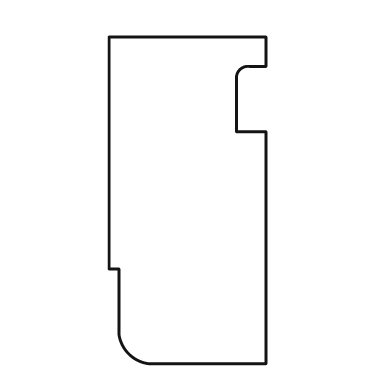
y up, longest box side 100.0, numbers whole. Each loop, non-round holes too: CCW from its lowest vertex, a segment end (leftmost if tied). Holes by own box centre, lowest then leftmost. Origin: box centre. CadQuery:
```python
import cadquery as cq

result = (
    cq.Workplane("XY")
    .moveTo(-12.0, -50.0)
    .lineTo(24.0, -50.0)
    .lineTo(24.0, 21.0)
    .lineTo(15.0, 21.0)
    .lineTo(15.0, 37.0)
    .threePointArc((16.0, 40.0), (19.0, 41.0))
    .lineTo(24.0, 41.0)
    .lineTo(24.0, 50.0)
    .lineTo(-24.0, 50.0)
    .lineTo(-24.0, -21.0)
    .lineTo(-21.0, -21.0)
    .lineTo(-21.0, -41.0)
    .threePointArc((-18.0, -47.0), (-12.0, -50.0))
    .close()
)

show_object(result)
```